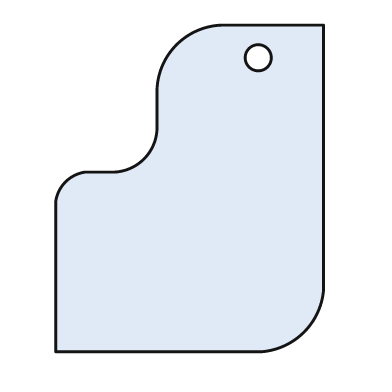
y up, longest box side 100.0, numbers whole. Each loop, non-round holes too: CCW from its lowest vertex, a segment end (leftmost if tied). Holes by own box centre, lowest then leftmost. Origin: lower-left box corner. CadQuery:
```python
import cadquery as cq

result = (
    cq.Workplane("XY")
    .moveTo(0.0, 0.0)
    .lineTo(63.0, 0.0)
    .threePointArc((76.0, 6.0), (82.0, 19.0))
    .lineTo(82.0, 100.0)
    .lineTo(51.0, 100.0)
    .threePointArc((37.0, 94.0), (31.0, 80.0))
    .lineTo(31.0, 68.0)
    .threePointArc((27.0, 59.0), (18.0, 55.0))
    .lineTo(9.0, 55.0)
    .threePointArc((3.0, 52.0), (0.0, 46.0))
    .close()
    .moveTo(62.0, 90.0)
    .circle(4.0)
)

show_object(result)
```